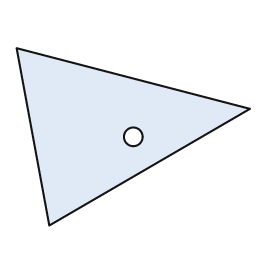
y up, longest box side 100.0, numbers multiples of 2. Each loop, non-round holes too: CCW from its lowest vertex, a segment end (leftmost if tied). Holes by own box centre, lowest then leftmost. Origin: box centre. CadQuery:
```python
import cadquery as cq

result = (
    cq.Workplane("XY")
    .moveTo(-36.0, -38.0)
    .lineTo(50.0, 12.0)
    .lineTo(-50.0, 38.0)
    .close()
    .moveTo(0.0, 0.0)
    .circle(4.0)
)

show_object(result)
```